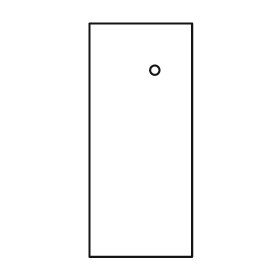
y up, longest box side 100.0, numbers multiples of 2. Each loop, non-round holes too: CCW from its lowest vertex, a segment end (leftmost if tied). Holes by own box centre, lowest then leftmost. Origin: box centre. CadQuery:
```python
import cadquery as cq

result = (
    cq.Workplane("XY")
    .moveTo(-22.0, -50.0)
    .lineTo(22.0, -50.0)
    .lineTo(22.0, 50.0)
    .lineTo(-22.0, 50.0)
    .close()
    .moveTo(6.0, 30.0)
    .circle(2.0)
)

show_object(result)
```